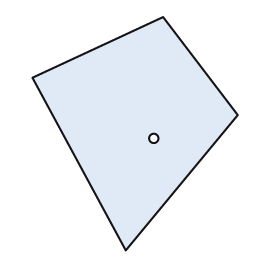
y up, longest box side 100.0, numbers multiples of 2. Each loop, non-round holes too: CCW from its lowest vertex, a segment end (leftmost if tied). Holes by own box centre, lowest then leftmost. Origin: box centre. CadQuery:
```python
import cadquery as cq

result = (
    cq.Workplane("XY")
    .moveTo(-4.0, -50.0)
    .lineTo(44.0, 8.0)
    .lineTo(12.0, 50.0)
    .lineTo(-44.0, 24.0)
    .close()
    .moveTo(8.0, -2.0)
    .circle(2.0)
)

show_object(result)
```